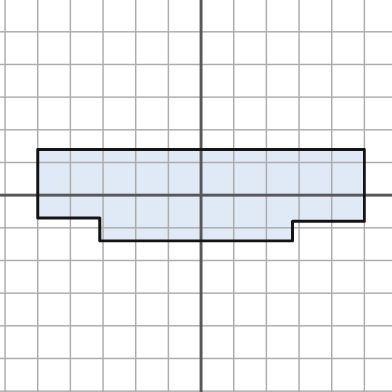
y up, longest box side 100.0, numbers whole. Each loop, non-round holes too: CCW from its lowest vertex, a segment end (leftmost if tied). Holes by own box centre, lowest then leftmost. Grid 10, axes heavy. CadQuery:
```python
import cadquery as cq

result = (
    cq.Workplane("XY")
    .moveTo(-31.0, -14.0)
    .lineTo(28.0, -14.0)
    .lineTo(28.0, -8.0)
    .lineTo(50.0, -8.0)
    .lineTo(50.0, 14.0)
    .lineTo(-50.0, 14.0)
    .lineTo(-50.0, -7.0)
    .lineTo(-31.0, -7.0)
    .close()
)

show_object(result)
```